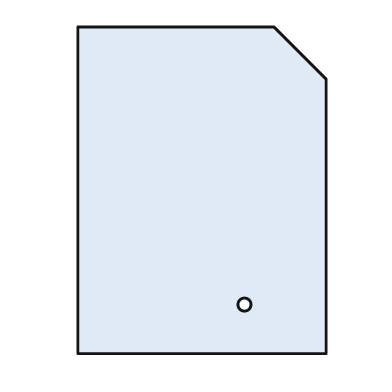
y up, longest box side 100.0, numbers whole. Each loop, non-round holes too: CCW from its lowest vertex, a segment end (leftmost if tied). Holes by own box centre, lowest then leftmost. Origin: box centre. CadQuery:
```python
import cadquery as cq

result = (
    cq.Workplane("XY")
    .moveTo(-38.0, -50.0)
    .lineTo(38.0, -50.0)
    .lineTo(38.0, 34.0)
    .lineTo(22.0, 50.0)
    .lineTo(-38.0, 50.0)
    .close()
    .moveTo(13.0, -35.0)
    .circle(2.0)
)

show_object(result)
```